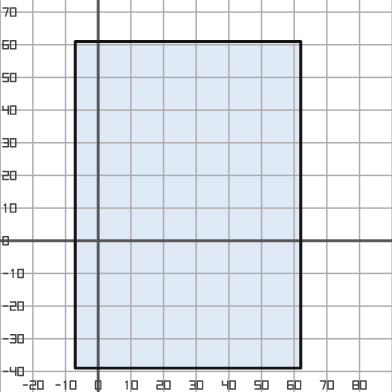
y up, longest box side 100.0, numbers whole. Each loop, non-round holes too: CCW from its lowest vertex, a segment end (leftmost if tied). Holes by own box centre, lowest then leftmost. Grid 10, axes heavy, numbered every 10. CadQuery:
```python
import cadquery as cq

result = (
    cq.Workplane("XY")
    .moveTo(-7.0, -39.0)
    .lineTo(62.0, -39.0)
    .lineTo(62.0, 61.0)
    .lineTo(-7.0, 61.0)
    .close()
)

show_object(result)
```